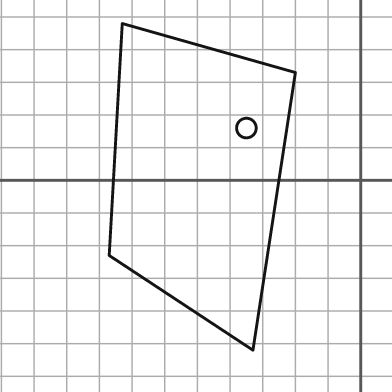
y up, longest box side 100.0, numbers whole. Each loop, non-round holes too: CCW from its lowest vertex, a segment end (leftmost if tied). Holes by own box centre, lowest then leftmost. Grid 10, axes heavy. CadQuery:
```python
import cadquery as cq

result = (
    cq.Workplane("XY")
    .moveTo(-33.0, -52.0)
    .lineTo(-20.0, 33.0)
    .lineTo(-73.0, 48.0)
    .lineTo(-77.0, -23.0)
    .close()
    .moveTo(-35.0, 16.0)
    .circle(3.0)
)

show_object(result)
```